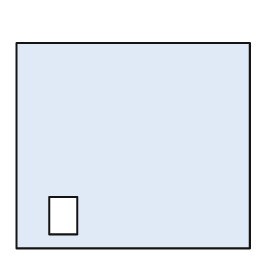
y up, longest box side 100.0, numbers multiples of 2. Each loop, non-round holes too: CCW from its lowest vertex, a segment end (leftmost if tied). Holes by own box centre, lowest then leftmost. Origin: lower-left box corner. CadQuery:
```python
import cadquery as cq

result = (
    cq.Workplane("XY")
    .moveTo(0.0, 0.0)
    .lineTo(100.0, 0.0)
    .lineTo(100.0, 88.0)
    .lineTo(0.0, 88.0)
    .close()
    .moveTo(14.0, 6.0)
    .lineTo(26.0, 6.0)
    .lineTo(26.0, 22.0)
    .lineTo(14.0, 22.0)
    .close()
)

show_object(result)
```